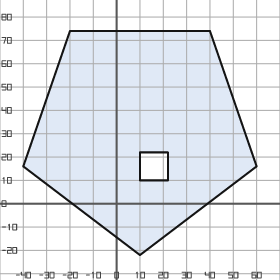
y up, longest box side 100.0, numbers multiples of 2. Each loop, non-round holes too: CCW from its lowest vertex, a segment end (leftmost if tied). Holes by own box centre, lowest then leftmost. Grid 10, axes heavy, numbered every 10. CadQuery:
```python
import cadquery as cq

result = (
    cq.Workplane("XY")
    .moveTo(10.0, -22.0)
    .lineTo(60.0, 16.0)
    .lineTo(40.0, 74.0)
    .lineTo(-20.0, 74.0)
    .lineTo(-40.0, 16.0)
    .close()
    .moveTo(10.0, 10.0)
    .lineTo(22.0, 10.0)
    .lineTo(22.0, 22.0)
    .lineTo(10.0, 22.0)
    .close()
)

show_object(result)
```